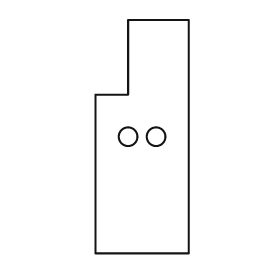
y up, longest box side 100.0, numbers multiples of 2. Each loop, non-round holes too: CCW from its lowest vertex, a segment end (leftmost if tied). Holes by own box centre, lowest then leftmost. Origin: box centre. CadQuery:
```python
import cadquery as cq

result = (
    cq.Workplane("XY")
    .moveTo(-20.0, -50.0)
    .lineTo(20.0, -50.0)
    .lineTo(20.0, 50.0)
    .lineTo(-6.0, 50.0)
    .lineTo(-6.0, 18.0)
    .lineTo(-20.0, 18.0)
    .close()
    .moveTo(-6.0, 0.0)
    .circle(4.0)
    .moveTo(6.0, 0.0)
    .circle(4.0)
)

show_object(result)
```